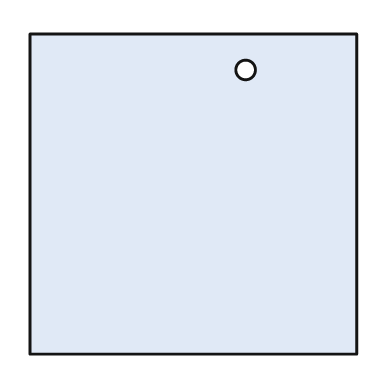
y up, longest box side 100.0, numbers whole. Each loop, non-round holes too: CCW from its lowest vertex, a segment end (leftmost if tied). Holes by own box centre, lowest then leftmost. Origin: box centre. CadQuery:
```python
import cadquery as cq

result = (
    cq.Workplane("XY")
    .moveTo(-50.0, -49.0)
    .lineTo(50.0, -49.0)
    .lineTo(50.0, 49.0)
    .lineTo(-50.0, 49.0)
    .close()
    .moveTo(16.0, 38.0)
    .circle(3.0)
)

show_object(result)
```